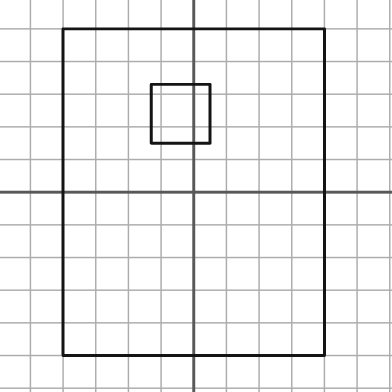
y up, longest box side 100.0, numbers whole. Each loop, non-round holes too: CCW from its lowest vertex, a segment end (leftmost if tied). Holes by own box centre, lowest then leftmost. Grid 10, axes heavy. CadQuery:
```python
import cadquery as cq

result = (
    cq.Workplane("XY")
    .moveTo(-40.0, -50.0)
    .lineTo(40.0, -50.0)
    .lineTo(40.0, 50.0)
    .lineTo(-40.0, 50.0)
    .close()
    .moveTo(-13.0, 15.0)
    .lineTo(5.0, 15.0)
    .lineTo(5.0, 33.0)
    .lineTo(-13.0, 33.0)
    .close()
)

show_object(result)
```